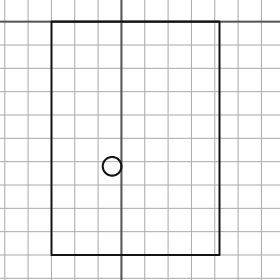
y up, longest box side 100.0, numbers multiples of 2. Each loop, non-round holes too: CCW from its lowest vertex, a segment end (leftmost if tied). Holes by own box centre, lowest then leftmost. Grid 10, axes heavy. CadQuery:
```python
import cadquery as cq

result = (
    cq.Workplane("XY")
    .moveTo(-30.0, -100.0)
    .lineTo(42.0, -100.0)
    .lineTo(42.0, 0.0)
    .lineTo(-30.0, 0.0)
    .close()
    .moveTo(-4.0, -62.0)
    .circle(4.0)
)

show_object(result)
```